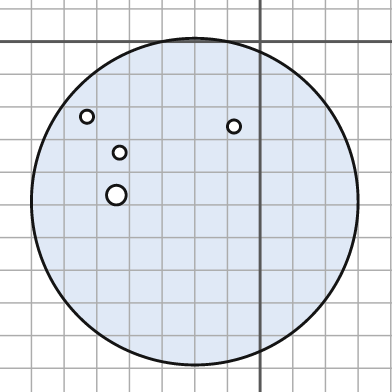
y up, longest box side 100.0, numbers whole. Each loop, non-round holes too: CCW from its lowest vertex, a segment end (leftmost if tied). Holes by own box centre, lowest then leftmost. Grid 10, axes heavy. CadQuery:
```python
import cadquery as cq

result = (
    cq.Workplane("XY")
    .moveTo(-20.0, -49.0)
    .circle(50.0)
    .moveTo(-44.0, -47.0)
    .circle(3.0)
    .moveTo(-43.0, -34.0)
    .circle(2.0)
    .moveTo(-8.0, -26.0)
    .circle(2.0)
    .moveTo(-53.0, -23.0)
    .circle(2.0)
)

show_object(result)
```